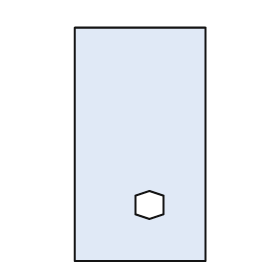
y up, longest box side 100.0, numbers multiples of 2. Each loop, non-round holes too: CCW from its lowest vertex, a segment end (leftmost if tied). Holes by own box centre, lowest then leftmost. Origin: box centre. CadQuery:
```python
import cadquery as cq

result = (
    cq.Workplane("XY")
    .moveTo(-28.0, -50.0)
    .lineTo(28.0, -50.0)
    .lineTo(28.0, 50.0)
    .lineTo(-28.0, 50.0)
    .close()
    .moveTo(4.0, -32.0)
    .lineTo(10.0, -30.0)
    .lineTo(10.0, -22.0)
    .lineTo(4.0, -20.0)
    .lineTo(-2.0, -22.0)
    .lineTo(-2.0, -30.0)
    .close()
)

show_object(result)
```